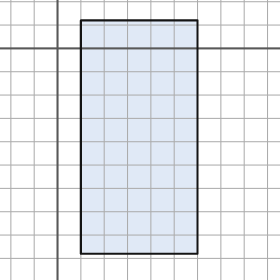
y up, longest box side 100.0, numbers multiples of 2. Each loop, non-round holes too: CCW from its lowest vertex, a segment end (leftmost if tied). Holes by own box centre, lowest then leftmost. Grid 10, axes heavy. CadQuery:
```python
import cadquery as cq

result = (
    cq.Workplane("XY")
    .moveTo(10.0, -88.0)
    .lineTo(60.0, -88.0)
    .lineTo(60.0, 12.0)
    .lineTo(10.0, 12.0)
    .close()
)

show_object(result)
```